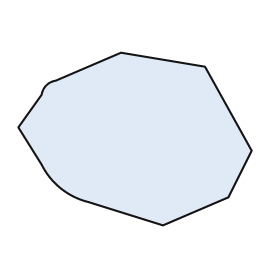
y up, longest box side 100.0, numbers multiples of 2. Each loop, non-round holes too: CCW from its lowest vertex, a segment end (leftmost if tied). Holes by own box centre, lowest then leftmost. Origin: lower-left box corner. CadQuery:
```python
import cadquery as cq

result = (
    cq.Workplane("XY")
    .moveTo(62.0, 0.0)
    .lineTo(90.0, 12.0)
    .lineTo(100.0, 32.0)
    .lineTo(80.0, 68.0)
    .lineTo(44.0, 74.0)
    .lineTo(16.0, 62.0)
    .threePointArc((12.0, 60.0), (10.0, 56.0))
    .lineTo(0.0, 42.0)
    .lineTo(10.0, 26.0)
    .threePointArc((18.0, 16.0), (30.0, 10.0))
    .close()
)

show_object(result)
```